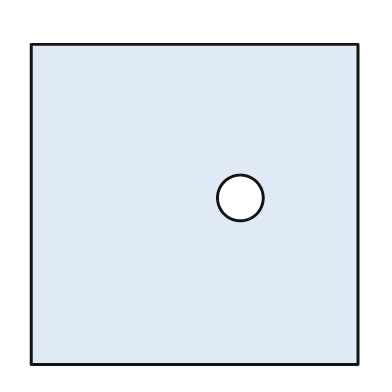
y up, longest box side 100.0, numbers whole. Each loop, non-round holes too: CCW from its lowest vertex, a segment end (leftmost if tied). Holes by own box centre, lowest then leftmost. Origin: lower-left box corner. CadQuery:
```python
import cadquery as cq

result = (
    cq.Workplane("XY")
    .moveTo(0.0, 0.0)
    .lineTo(100.0, 0.0)
    .lineTo(100.0, 98.0)
    .lineTo(0.0, 98.0)
    .close()
    .moveTo(64.0, 51.0)
    .circle(7.0)
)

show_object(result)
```